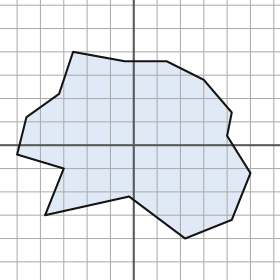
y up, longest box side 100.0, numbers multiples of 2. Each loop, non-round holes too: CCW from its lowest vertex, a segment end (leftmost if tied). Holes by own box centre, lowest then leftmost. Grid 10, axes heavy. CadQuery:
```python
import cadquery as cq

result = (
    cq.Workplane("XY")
    .moveTo(22.0, -40.0)
    .lineTo(42.0, -32.0)
    .lineTo(50.0, -12.0)
    .lineTo(40.0, 4.0)
    .lineTo(42.0, 14.0)
    .lineTo(30.0, 28.0)
    .lineTo(14.0, 36.0)
    .lineTo(-4.0, 36.0)
    .lineTo(-26.0, 40.0)
    .lineTo(-32.0, 22.0)
    .lineTo(-46.0, 12.0)
    .lineTo(-50.0, -4.0)
    .lineTo(-30.0, -10.0)
    .lineTo(-38.0, -30.0)
    .lineTo(-2.0, -22.0)
    .close()
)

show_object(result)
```